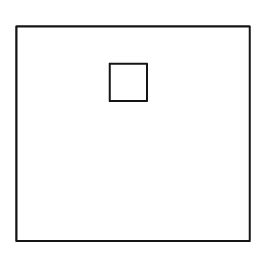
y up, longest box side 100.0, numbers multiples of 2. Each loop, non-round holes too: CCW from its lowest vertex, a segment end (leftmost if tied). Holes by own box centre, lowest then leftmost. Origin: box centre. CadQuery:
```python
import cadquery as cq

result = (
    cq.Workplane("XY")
    .moveTo(-50.0, -46.0)
    .lineTo(50.0, -46.0)
    .lineTo(50.0, 46.0)
    .lineTo(-50.0, 46.0)
    .close()
    .moveTo(-10.0, 14.0)
    .lineTo(6.0, 14.0)
    .lineTo(6.0, 30.0)
    .lineTo(-10.0, 30.0)
    .close()
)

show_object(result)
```